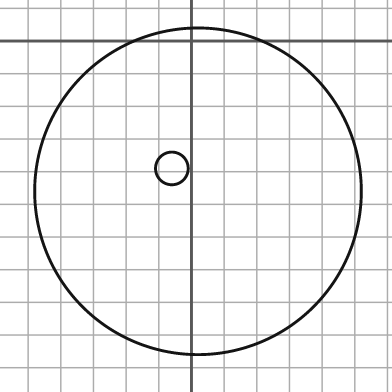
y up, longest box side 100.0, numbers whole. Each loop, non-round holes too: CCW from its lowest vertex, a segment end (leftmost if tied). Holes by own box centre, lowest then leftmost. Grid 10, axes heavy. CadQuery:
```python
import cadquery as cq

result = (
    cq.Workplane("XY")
    .moveTo(2.0, -46.0)
    .circle(50.0)
    .moveTo(-6.0, -39.0)
    .circle(5.0)
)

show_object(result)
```